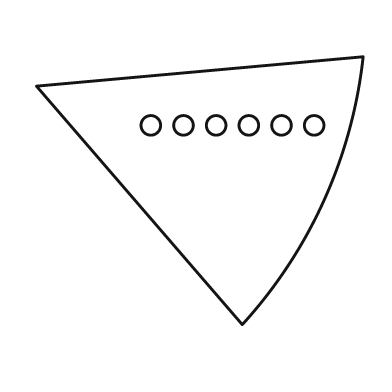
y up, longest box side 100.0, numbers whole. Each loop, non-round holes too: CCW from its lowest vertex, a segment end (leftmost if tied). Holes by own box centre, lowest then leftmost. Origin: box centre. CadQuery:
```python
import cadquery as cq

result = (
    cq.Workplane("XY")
    .moveTo(13.0, -41.0)
    .threePointArc((38.0, -3.0), (50.0, 41.0))
    .lineTo(-50.0, 32.0)
    .close()
    .moveTo(-15.0, 20.0)
    .circle(3.0)
    .moveTo(-5.0, 20.0)
    .circle(3.0)
    .moveTo(5.0, 20.0)
    .circle(3.0)
    .moveTo(15.0, 20.0)
    .circle(3.0)
    .moveTo(25.0, 20.0)
    .circle(3.0)
    .moveTo(35.0, 20.0)
    .circle(3.0)
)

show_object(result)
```